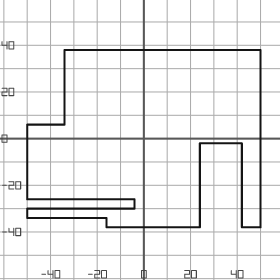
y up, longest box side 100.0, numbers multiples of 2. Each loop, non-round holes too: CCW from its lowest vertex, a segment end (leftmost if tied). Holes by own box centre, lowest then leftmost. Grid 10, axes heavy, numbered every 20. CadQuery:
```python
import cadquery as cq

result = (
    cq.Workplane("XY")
    .moveTo(-16.0, -38.0)
    .lineTo(24.0, -38.0)
    .lineTo(24.0, -2.0)
    .lineTo(42.0, -2.0)
    .lineTo(42.0, -38.0)
    .lineTo(50.0, -38.0)
    .lineTo(50.0, 38.0)
    .lineTo(-34.0, 38.0)
    .lineTo(-34.0, 6.0)
    .lineTo(-50.0, 6.0)
    .lineTo(-50.0, -26.0)
    .lineTo(-4.0, -26.0)
    .lineTo(-4.0, -30.0)
    .lineTo(-50.0, -30.0)
    .lineTo(-50.0, -34.0)
    .lineTo(-16.0, -34.0)
    .close()
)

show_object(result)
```